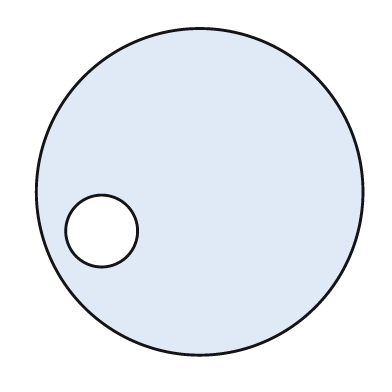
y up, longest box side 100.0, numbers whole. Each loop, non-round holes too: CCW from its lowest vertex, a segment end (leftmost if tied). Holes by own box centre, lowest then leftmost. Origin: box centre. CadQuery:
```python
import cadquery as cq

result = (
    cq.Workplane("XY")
    .moveTo(0.0, 0.0)
    .circle(50.0)
    .moveTo(-30.0, -12.0)
    .circle(11.0)
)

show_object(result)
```